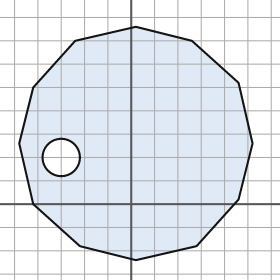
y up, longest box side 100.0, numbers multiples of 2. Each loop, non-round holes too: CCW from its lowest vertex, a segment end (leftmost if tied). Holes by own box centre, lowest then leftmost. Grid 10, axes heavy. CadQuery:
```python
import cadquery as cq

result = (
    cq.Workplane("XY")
    .moveTo(2.0, -24.0)
    .lineTo(28.0, -18.0)
    .lineTo(46.0, 2.0)
    .lineTo(52.0, 26.0)
    .lineTo(46.0, 52.0)
    .lineTo(26.0, 70.0)
    .lineTo(2.0, 76.0)
    .lineTo(-24.0, 70.0)
    .lineTo(-42.0, 50.0)
    .lineTo(-48.0, 26.0)
    .lineTo(-42.0, 0.0)
    .lineTo(-22.0, -18.0)
    .close()
    .moveTo(-30.0, 20.0)
    .circle(8.0)
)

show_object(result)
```